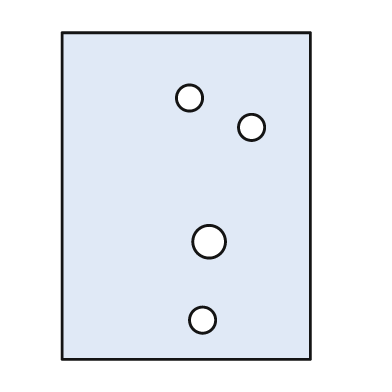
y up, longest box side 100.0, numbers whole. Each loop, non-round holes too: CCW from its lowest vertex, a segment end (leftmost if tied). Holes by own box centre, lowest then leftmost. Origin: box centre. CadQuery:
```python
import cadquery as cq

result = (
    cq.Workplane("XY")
    .moveTo(-38.0, -50.0)
    .lineTo(38.0, -50.0)
    .lineTo(38.0, 50.0)
    .lineTo(-38.0, 50.0)
    .close()
    .moveTo(5.0, -38.0)
    .circle(4.0)
    .moveTo(7.0, -14.0)
    .circle(5.0)
    .moveTo(20.0, 21.0)
    .circle(4.0)
    .moveTo(1.0, 30.0)
    .circle(4.0)
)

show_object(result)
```